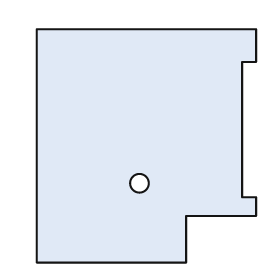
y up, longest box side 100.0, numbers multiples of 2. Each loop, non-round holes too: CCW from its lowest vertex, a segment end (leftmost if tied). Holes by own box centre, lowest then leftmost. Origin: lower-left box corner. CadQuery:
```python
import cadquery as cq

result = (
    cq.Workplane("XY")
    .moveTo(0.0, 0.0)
    .lineTo(64.0, 0.0)
    .lineTo(64.0, 20.0)
    .lineTo(94.0, 20.0)
    .lineTo(94.0, 28.0)
    .lineTo(88.0, 28.0)
    .lineTo(88.0, 86.0)
    .lineTo(94.0, 86.0)
    .lineTo(94.0, 100.0)
    .lineTo(0.0, 100.0)
    .close()
    .moveTo(44.0, 34.0)
    .circle(4.0)
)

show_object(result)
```